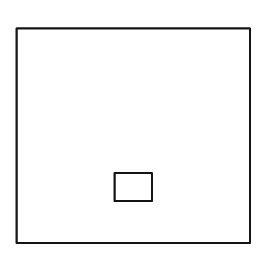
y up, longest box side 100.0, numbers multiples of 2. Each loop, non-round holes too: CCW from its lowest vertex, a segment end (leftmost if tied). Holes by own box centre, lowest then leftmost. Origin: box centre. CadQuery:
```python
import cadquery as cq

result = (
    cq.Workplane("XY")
    .moveTo(-50.0, -46.0)
    .lineTo(50.0, -46.0)
    .lineTo(50.0, 46.0)
    .lineTo(-50.0, 46.0)
    .close()
    .moveTo(-8.0, -28.0)
    .lineTo(8.0, -28.0)
    .lineTo(8.0, -16.0)
    .lineTo(-8.0, -16.0)
    .close()
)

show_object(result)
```